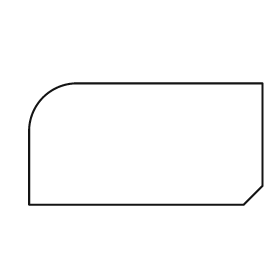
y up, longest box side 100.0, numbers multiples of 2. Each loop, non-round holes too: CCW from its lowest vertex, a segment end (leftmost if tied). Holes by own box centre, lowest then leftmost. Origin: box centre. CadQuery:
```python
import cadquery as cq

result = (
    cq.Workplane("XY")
    .moveTo(-50.0, -26.0)
    .lineTo(42.0, -26.0)
    .lineTo(50.0, -18.0)
    .lineTo(50.0, 26.0)
    .lineTo(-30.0, 26.0)
    .threePointArc((-44.0, 20.0), (-50.0, 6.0))
    .close()
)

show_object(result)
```